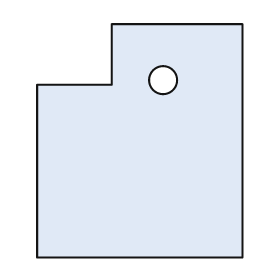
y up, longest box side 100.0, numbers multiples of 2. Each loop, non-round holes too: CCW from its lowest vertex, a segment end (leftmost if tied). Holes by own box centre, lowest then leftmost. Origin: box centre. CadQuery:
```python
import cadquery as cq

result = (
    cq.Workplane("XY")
    .moveTo(-44.0, -50.0)
    .lineTo(44.0, -50.0)
    .lineTo(44.0, 50.0)
    .lineTo(-12.0, 50.0)
    .lineTo(-12.0, 24.0)
    .lineTo(-44.0, 24.0)
    .close()
    .moveTo(10.0, 26.0)
    .circle(6.0)
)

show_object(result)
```